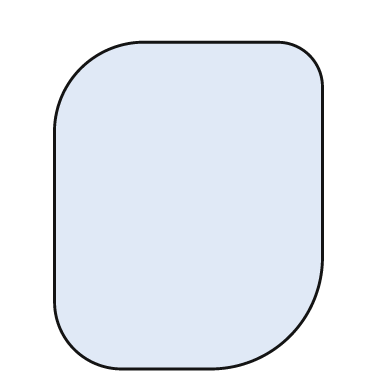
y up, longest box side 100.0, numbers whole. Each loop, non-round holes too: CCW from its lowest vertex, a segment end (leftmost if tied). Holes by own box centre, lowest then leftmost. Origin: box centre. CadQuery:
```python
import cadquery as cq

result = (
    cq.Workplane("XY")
    .moveTo(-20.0, -50.0)
    .lineTo(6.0, -50.0)
    .threePointArc((31.0, -40.0), (41.0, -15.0))
    .lineTo(41.0, 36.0)
    .threePointArc((37.0, 46.0), (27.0, 50.0))
    .lineTo(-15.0, 50.0)
    .threePointArc((-33.0, 42.0), (-41.0, 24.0))
    .lineTo(-41.0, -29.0)
    .threePointArc((-35.0, -44.0), (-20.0, -50.0))
    .close()
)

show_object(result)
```